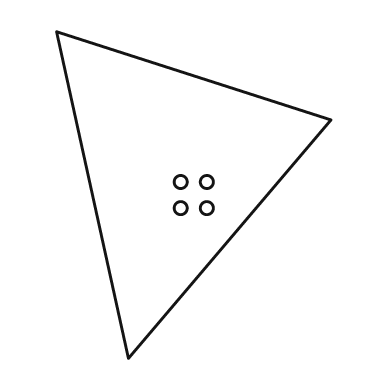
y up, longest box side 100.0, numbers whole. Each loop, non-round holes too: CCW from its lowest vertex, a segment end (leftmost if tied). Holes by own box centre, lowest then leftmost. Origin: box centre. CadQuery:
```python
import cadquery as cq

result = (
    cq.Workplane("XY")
    .moveTo(-20.0, -50.0)
    .lineTo(42.0, 23.0)
    .lineTo(-42.0, 50.0)
    .close()
    .moveTo(-4.0, -4.0)
    .circle(2.0)
    .moveTo(4.0, -4.0)
    .circle(2.0)
    .moveTo(-4.0, 4.0)
    .circle(2.0)
    .moveTo(4.0, 4.0)
    .circle(2.0)
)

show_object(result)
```